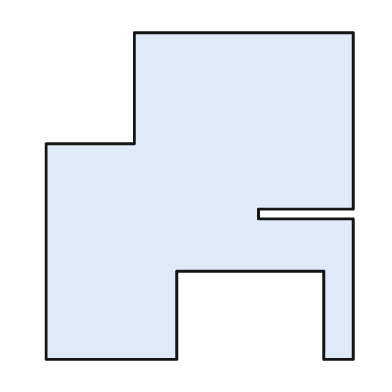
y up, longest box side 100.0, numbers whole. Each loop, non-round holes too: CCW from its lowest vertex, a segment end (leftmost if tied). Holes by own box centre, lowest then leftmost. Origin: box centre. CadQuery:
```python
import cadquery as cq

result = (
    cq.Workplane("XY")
    .moveTo(-47.0, -50.0)
    .lineTo(-7.0, -50.0)
    .lineTo(-7.0, -23.0)
    .lineTo(38.0, -23.0)
    .lineTo(38.0, -50.0)
    .lineTo(47.0, -50.0)
    .lineTo(47.0, -7.0)
    .lineTo(18.0, -7.0)
    .lineTo(18.0, -4.0)
    .lineTo(47.0, -4.0)
    .lineTo(47.0, 50.0)
    .lineTo(-20.0, 50.0)
    .lineTo(-20.0, 16.0)
    .lineTo(-47.0, 16.0)
    .close()
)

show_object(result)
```